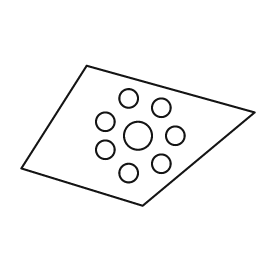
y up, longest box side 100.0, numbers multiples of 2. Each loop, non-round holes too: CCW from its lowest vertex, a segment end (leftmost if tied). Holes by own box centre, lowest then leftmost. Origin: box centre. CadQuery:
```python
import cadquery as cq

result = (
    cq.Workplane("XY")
    .moveTo(2.0, -30.0)
    .lineTo(50.0, 10.0)
    .lineTo(-22.0, 30.0)
    .lineTo(-50.0, -14.0)
    .close()
    .moveTo(-4.0, -16.0)
    .circle(4.0)
    .moveTo(10.0, -12.0)
    .circle(4.0)
    .moveTo(-14.0, -6.0)
    .circle(4.0)
    .moveTo(0.0, 0.0)
    .circle(6.0)
    .moveTo(16.0, 0.0)
    .circle(4.0)
    .moveTo(-14.0, 6.0)
    .circle(4.0)
    .moveTo(10.0, 12.0)
    .circle(4.0)
    .moveTo(-4.0, 16.0)
    .circle(4.0)
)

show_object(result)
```